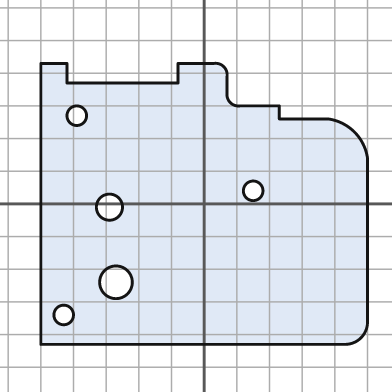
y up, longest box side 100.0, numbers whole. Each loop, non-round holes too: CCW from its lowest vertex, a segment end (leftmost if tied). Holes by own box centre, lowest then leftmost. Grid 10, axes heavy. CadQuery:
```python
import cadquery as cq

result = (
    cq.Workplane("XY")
    .moveTo(-50.0, -43.0)
    .lineTo(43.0, -43.0)
    .threePointArc((48.0, -41.0), (50.0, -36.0))
    .lineTo(50.0, 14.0)
    .threePointArc((46.0, 22.0), (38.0, 26.0))
    .lineTo(23.0, 26.0)
    .lineTo(23.0, 30.0)
    .lineTo(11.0, 30.0)
    .threePointArc((8.0, 31.0), (7.0, 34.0))
    .lineTo(7.0, 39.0)
    .threePointArc((6.0, 42.0), (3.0, 43.0))
    .lineTo(-8.0, 43.0)
    .lineTo(-8.0, 37.0)
    .lineTo(-42.0, 37.0)
    .lineTo(-42.0, 43.0)
    .lineTo(-50.0, 43.0)
    .close()
    .moveTo(-43.0, -34.0)
    .circle(3.0)
    .moveTo(-27.0, -24.0)
    .circle(5.0)
    .moveTo(-29.0, -1.0)
    .circle(4.0)
    .moveTo(15.0, 4.0)
    .circle(3.0)
    .moveTo(-39.0, 27.0)
    .circle(3.0)
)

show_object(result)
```